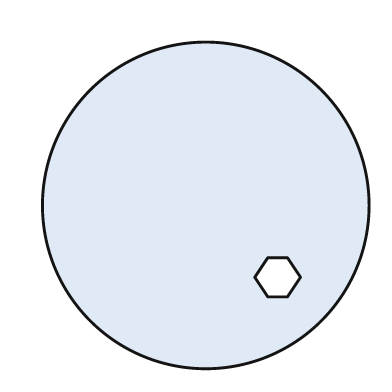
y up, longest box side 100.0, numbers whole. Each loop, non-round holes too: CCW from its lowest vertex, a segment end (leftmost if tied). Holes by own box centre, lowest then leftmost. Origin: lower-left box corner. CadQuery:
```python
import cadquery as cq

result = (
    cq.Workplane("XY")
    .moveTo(50.0, 50.0)
    .circle(50.0)
    .moveTo(69.0, 22.0)
    .lineTo(75.0, 22.0)
    .lineTo(79.0, 28.0)
    .lineTo(75.0, 34.0)
    .lineTo(69.0, 34.0)
    .lineTo(65.0, 28.0)
    .close()
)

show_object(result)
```